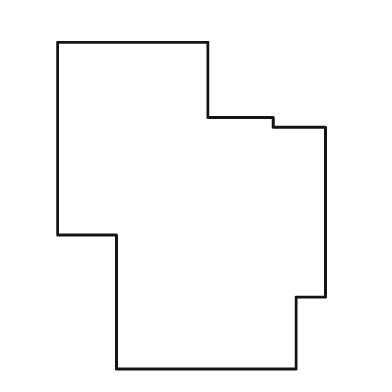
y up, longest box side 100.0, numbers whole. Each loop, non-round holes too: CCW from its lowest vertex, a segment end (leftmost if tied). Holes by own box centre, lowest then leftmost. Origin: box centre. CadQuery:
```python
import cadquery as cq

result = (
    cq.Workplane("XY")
    .moveTo(-23.0, -50.0)
    .lineTo(32.0, -50.0)
    .lineTo(32.0, -28.0)
    .lineTo(41.0, -28.0)
    .lineTo(41.0, 24.0)
    .lineTo(25.0, 24.0)
    .lineTo(25.0, 27.0)
    .lineTo(5.0, 27.0)
    .lineTo(5.0, 50.0)
    .lineTo(-41.0, 50.0)
    .lineTo(-41.0, -9.0)
    .lineTo(-23.0, -9.0)
    .close()
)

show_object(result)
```